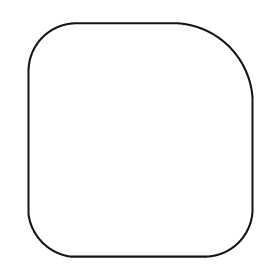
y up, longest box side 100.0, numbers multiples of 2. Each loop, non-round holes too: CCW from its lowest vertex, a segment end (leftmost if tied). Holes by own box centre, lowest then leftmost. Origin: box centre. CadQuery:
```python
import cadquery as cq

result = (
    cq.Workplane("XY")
    .moveTo(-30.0, -50.0)
    .lineTo(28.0, -50.0)
    .threePointArc((42.0, -44.0), (48.0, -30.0))
    .lineTo(48.0, 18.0)
    .threePointArc((38.0, 40.0), (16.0, 50.0))
    .lineTo(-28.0, 50.0)
    .threePointArc((-42.0, 44.0), (-48.0, 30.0))
    .lineTo(-48.0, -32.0)
    .threePointArc((-42.0, -44.0), (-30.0, -50.0))
    .close()
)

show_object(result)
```